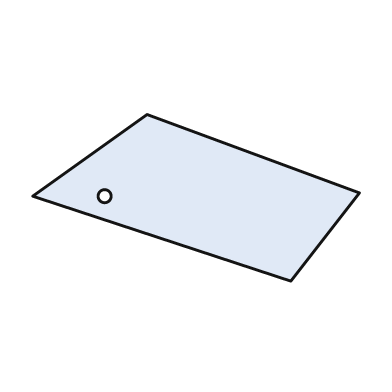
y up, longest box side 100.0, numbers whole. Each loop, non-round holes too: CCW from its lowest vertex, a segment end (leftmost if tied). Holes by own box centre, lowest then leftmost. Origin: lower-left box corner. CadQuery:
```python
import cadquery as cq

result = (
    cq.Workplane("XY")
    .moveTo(79.0, 0.0)
    .lineTo(100.0, 27.0)
    .lineTo(35.0, 51.0)
    .lineTo(0.0, 26.0)
    .close()
    .moveTo(22.0, 26.0)
    .circle(2.0)
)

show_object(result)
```